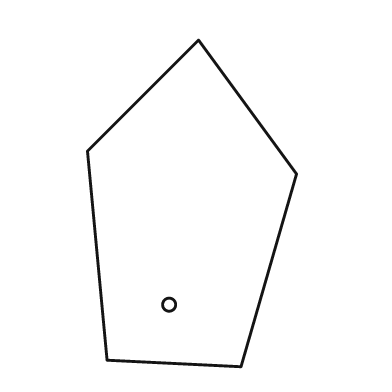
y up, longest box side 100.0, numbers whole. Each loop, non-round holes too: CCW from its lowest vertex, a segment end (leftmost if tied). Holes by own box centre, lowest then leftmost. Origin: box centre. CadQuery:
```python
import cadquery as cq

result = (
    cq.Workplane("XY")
    .moveTo(15.0, -50.0)
    .lineTo(32.0, 9.0)
    .lineTo(2.0, 50.0)
    .lineTo(-32.0, 16.0)
    .lineTo(-26.0, -48.0)
    .close()
    .moveTo(-7.0, -31.0)
    .circle(2.0)
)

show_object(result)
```